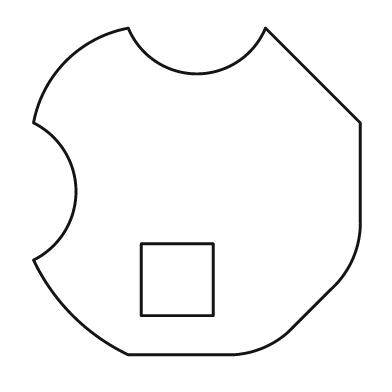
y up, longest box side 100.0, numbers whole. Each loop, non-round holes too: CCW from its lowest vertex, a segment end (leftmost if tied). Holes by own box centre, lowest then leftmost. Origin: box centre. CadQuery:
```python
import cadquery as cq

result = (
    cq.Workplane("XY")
    .moveTo(-21.0, -50.0)
    .lineTo(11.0, -50.0)
    .threePointArc((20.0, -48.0), (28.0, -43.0))
    .lineTo(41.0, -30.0)
    .threePointArc((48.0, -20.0), (50.0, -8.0))
    .lineTo(50.0, 21.0)
    .lineTo(21.0, 50.0)
    .threePointArc((0.0, 36.0), (-21.0, 50.0))
    .threePointArc((-40.0, 40.0), (-50.0, 21.0))
    .threePointArc((-37.0, 0.0), (-50.0, -21.0))
    .threePointArc((-38.0, -38.0), (-21.0, -50.0))
    .close()
    .moveTo(-17.0, -38.0)
    .lineTo(5.0, -38.0)
    .lineTo(5.0, -16.0)
    .lineTo(-17.0, -16.0)
    .close()
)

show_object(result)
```